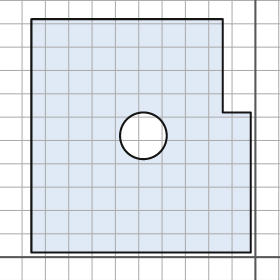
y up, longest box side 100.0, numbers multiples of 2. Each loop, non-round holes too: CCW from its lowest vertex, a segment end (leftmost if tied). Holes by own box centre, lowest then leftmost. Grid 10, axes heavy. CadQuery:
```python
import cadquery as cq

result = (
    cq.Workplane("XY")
    .moveTo(-96.0, 2.0)
    .lineTo(-2.0, 2.0)
    .lineTo(-2.0, 62.0)
    .lineTo(-14.0, 62.0)
    .lineTo(-14.0, 102.0)
    .lineTo(-96.0, 102.0)
    .close()
    .moveTo(-48.0, 52.0)
    .circle(10.0)
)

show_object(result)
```